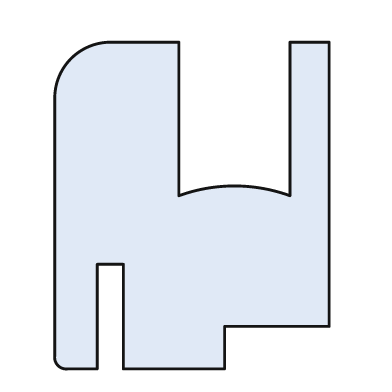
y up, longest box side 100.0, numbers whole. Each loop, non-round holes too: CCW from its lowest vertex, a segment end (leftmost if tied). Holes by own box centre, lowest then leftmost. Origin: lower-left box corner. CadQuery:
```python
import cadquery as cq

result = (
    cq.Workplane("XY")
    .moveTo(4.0, 0.0)
    .lineTo(13.0, 0.0)
    .lineTo(13.0, 32.0)
    .lineTo(21.0, 32.0)
    .lineTo(21.0, 0.0)
    .lineTo(52.0, 0.0)
    .lineTo(52.0, 13.0)
    .lineTo(84.0, 13.0)
    .lineTo(84.0, 100.0)
    .lineTo(72.0, 100.0)
    .lineTo(72.0, 53.0)
    .threePointArc((55.0, 56.0), (38.0, 53.0))
    .lineTo(38.0, 100.0)
    .lineTo(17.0, 100.0)
    .threePointArc((5.0, 95.0), (0.0, 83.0))
    .lineTo(0.0, 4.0)
    .threePointArc((1.0, 1.0), (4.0, 0.0))
    .close()
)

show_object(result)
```